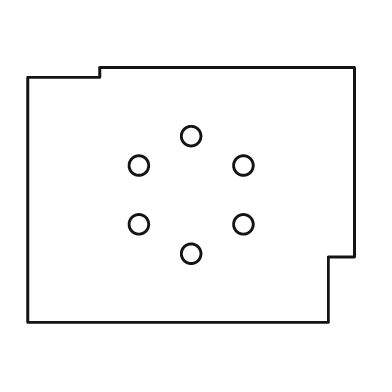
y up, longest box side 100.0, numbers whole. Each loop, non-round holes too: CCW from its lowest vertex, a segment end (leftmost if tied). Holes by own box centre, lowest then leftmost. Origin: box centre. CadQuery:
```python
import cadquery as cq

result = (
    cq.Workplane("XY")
    .moveTo(-50.0, -39.0)
    .lineTo(42.0, -39.0)
    .lineTo(42.0, -19.0)
    .lineTo(50.0, -19.0)
    .lineTo(50.0, 39.0)
    .lineTo(-28.0, 39.0)
    .lineTo(-28.0, 36.0)
    .lineTo(-50.0, 36.0)
    .close()
    .moveTo(0.0, -18.0)
    .circle(3.0)
    .moveTo(-16.0, -9.0)
    .circle(3.0)
    .moveTo(16.0, -9.0)
    .circle(3.0)
    .moveTo(-16.0, 9.0)
    .circle(3.0)
    .moveTo(16.0, 9.0)
    .circle(3.0)
    .moveTo(0.0, 18.0)
    .circle(3.0)
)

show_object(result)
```